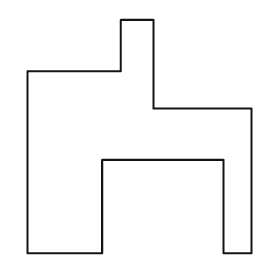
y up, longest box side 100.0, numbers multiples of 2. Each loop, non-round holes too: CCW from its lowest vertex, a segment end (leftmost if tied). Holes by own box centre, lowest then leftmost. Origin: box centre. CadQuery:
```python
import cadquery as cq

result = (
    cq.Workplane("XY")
    .moveTo(-48.0, -50.0)
    .lineTo(-16.0, -50.0)
    .lineTo(-16.0, -10.0)
    .lineTo(36.0, -10.0)
    .lineTo(36.0, -50.0)
    .lineTo(48.0, -50.0)
    .lineTo(48.0, 12.0)
    .lineTo(6.0, 12.0)
    .lineTo(6.0, 50.0)
    .lineTo(-8.0, 50.0)
    .lineTo(-8.0, 28.0)
    .lineTo(-48.0, 28.0)
    .close()
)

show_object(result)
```